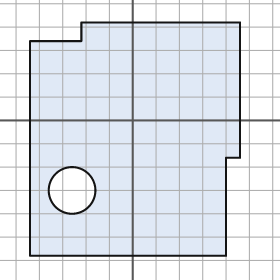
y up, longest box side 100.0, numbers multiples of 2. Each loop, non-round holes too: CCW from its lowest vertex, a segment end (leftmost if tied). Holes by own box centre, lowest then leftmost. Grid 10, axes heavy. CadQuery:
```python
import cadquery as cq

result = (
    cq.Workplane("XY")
    .moveTo(-44.0, -58.0)
    .lineTo(40.0, -58.0)
    .lineTo(40.0, -16.0)
    .lineTo(46.0, -16.0)
    .lineTo(46.0, 42.0)
    .lineTo(-22.0, 42.0)
    .lineTo(-22.0, 34.0)
    .lineTo(-44.0, 34.0)
    .close()
    .moveTo(-26.0, -30.0)
    .circle(10.0)
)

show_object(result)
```